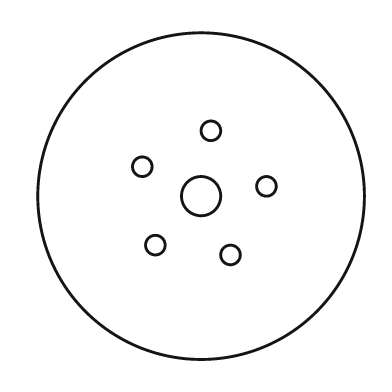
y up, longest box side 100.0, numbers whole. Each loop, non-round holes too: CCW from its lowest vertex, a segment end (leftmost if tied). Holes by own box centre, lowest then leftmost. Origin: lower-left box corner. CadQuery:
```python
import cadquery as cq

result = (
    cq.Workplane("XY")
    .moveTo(50.0, 50.0)
    .circle(50.0)
    .moveTo(59.0, 32.0)
    .circle(3.0)
    .moveTo(36.0, 35.0)
    .circle(3.0)
    .moveTo(50.0, 50.0)
    .circle(6.0)
    .moveTo(70.0, 53.0)
    .circle(3.0)
    .moveTo(32.0, 59.0)
    .circle(3.0)
    .moveTo(53.0, 70.0)
    .circle(3.0)
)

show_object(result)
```